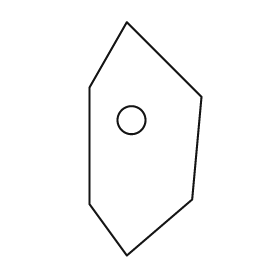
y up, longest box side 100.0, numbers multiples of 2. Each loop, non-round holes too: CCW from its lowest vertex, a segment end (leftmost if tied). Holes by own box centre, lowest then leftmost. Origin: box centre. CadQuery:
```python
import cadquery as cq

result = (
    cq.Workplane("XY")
    .moveTo(-8.0, -50.0)
    .lineTo(20.0, -26.0)
    .lineTo(24.0, 18.0)
    .lineTo(-8.0, 50.0)
    .lineTo(-24.0, 22.0)
    .lineTo(-24.0, -28.0)
    .close()
    .moveTo(-6.0, 8.0)
    .circle(6.0)
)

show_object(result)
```